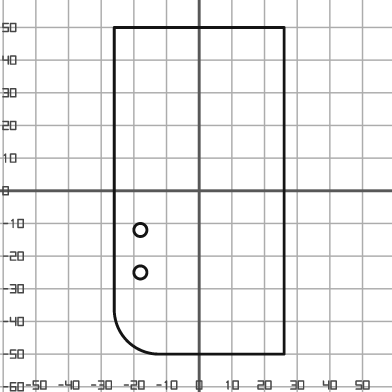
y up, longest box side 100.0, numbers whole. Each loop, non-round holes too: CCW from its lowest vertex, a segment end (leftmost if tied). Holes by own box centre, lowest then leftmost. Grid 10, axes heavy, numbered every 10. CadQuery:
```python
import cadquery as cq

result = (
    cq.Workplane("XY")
    .moveTo(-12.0, -50.0)
    .lineTo(26.0, -50.0)
    .lineTo(26.0, 50.0)
    .lineTo(-26.0, 50.0)
    .lineTo(-26.0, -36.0)
    .threePointArc((-22.0, -46.0), (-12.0, -50.0))
    .close()
    .moveTo(-18.0, -25.0)
    .circle(2.0)
    .moveTo(-18.0, -12.0)
    .circle(2.0)
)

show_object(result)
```